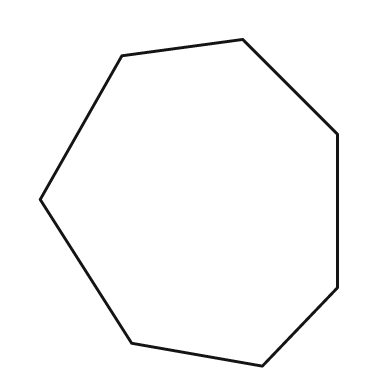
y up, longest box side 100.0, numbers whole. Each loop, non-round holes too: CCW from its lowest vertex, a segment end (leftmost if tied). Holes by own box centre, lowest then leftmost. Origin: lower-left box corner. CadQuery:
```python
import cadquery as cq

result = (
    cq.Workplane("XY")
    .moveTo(68.0, 0.0)
    .lineTo(91.0, 24.0)
    .lineTo(91.0, 71.0)
    .lineTo(62.0, 100.0)
    .lineTo(25.0, 95.0)
    .lineTo(0.0, 51.0)
    .lineTo(28.0, 7.0)
    .close()
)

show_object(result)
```